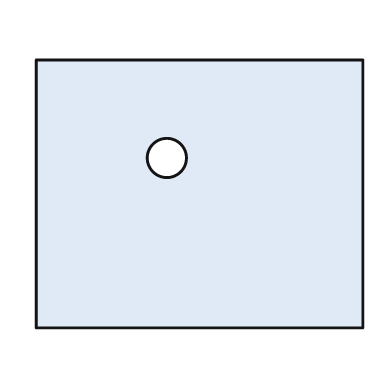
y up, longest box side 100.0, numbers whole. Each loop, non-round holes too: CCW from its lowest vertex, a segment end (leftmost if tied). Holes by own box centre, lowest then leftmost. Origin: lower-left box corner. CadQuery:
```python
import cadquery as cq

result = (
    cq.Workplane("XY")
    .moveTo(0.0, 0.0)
    .lineTo(100.0, 0.0)
    .lineTo(100.0, 82.0)
    .lineTo(0.0, 82.0)
    .close()
    .moveTo(40.0, 52.0)
    .circle(6.0)
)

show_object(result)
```